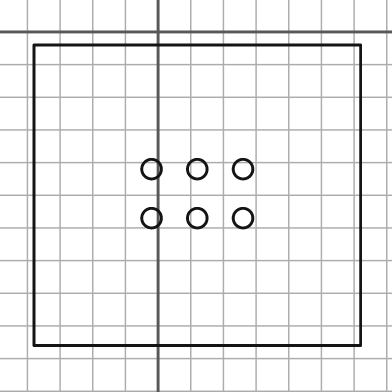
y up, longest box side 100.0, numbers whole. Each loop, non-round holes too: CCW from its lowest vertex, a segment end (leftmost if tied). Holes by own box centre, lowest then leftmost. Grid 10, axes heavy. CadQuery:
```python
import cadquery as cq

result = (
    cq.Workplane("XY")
    .moveTo(-38.0, -96.0)
    .lineTo(62.0, -96.0)
    .lineTo(62.0, -4.0)
    .lineTo(-38.0, -4.0)
    .close()
    .moveTo(-2.0, -57.0)
    .circle(3.0)
    .moveTo(12.0, -57.0)
    .circle(3.0)
    .moveTo(26.0, -57.0)
    .circle(3.0)
    .moveTo(-2.0, -42.0)
    .circle(3.0)
    .moveTo(12.0, -42.0)
    .circle(3.0)
    .moveTo(26.0, -42.0)
    .circle(3.0)
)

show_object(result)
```